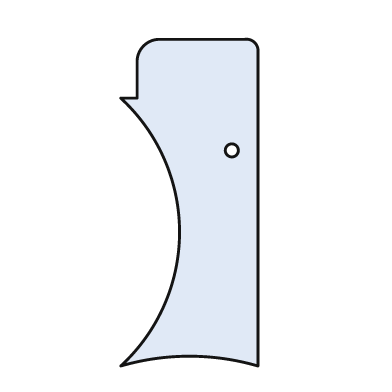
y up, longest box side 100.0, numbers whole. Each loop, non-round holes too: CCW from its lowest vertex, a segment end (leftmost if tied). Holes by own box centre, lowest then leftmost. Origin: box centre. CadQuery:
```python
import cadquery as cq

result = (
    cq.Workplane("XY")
    .moveTo(-21.0, -50.0)
    .threePointArc((0.0, -47.0), (21.0, -50.0))
    .lineTo(21.0, 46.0)
    .threePointArc((20.0, 49.0), (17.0, 50.0))
    .lineTo(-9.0, 50.0)
    .threePointArc((-14.0, 48.0), (-16.0, 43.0))
    .lineTo(-16.0, 32.0)
    .lineTo(-21.0, 32.0)
    .threePointArc((-3.0, -9.0), (-21.0, -50.0))
    .close()
    .moveTo(13.0, 16.0)
    .circle(2.0)
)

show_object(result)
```